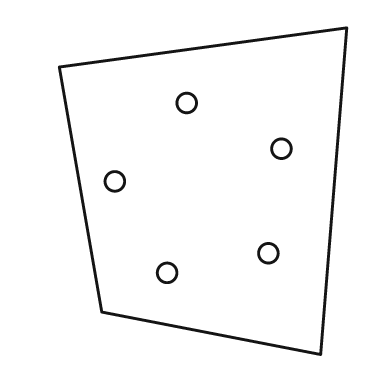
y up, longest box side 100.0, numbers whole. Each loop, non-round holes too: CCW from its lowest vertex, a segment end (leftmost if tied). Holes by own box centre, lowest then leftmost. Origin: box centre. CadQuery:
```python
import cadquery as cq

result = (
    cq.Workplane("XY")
    .moveTo(36.0, -50.0)
    .lineTo(44.0, 50.0)
    .lineTo(-44.0, 38.0)
    .lineTo(-31.0, -37.0)
    .close()
    .moveTo(-11.0, -25.0)
    .circle(3.0)
    .moveTo(20.0, -19.0)
    .circle(3.0)
    .moveTo(-27.0, 3.0)
    .circle(3.0)
    .moveTo(24.0, 13.0)
    .circle(3.0)
    .moveTo(-5.0, 27.0)
    .circle(3.0)
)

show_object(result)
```